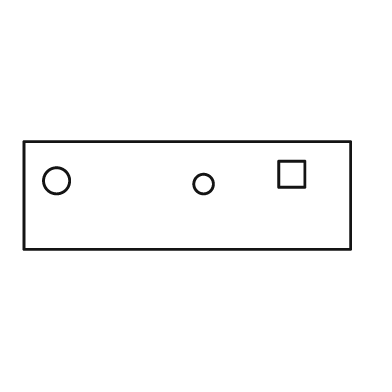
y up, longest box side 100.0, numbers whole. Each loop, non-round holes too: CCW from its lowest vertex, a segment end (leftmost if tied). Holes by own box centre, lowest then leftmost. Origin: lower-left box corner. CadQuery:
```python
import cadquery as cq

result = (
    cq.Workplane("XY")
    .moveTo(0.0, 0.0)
    .lineTo(100.0, 0.0)
    .lineTo(100.0, 33.0)
    .lineTo(0.0, 33.0)
    .close()
    .moveTo(55.0, 20.0)
    .circle(3.0)
    .moveTo(10.0, 21.0)
    .circle(4.0)
    .moveTo(78.0, 19.0)
    .lineTo(86.0, 19.0)
    .lineTo(86.0, 27.0)
    .lineTo(78.0, 27.0)
    .close()
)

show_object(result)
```